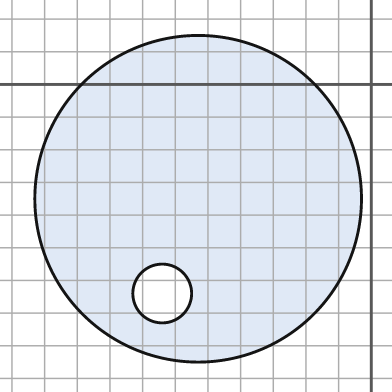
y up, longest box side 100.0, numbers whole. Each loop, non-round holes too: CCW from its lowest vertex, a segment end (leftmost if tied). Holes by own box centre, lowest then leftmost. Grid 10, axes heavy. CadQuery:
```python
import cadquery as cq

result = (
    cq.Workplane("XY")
    .moveTo(-53.0, -35.0)
    .circle(50.0)
    .moveTo(-64.0, -64.0)
    .circle(9.0)
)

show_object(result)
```